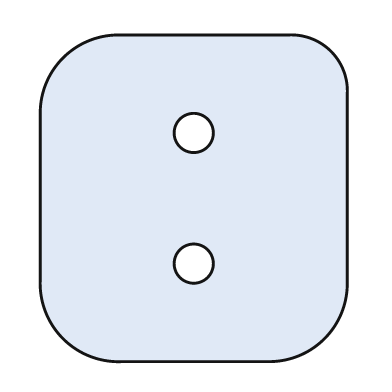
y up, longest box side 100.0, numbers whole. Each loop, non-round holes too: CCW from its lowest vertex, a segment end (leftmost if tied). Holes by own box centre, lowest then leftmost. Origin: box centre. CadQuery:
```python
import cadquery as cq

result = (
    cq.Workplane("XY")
    .moveTo(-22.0, -50.0)
    .lineTo(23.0, -50.0)
    .threePointArc((40.0, -43.0), (47.0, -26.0))
    .lineTo(47.0, 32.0)
    .threePointArc((42.0, 45.0), (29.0, 50.0))
    .lineTo(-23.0, 50.0)
    .threePointArc((-40.0, 43.0), (-47.0, 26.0))
    .lineTo(-47.0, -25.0)
    .threePointArc((-40.0, -43.0), (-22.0, -50.0))
    .close()
    .moveTo(0.0, -20.0)
    .circle(6.0)
    .moveTo(0.0, 20.0)
    .circle(6.0)
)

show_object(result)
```